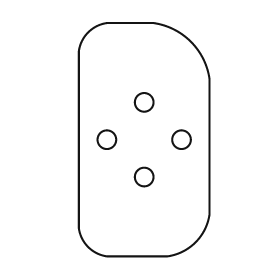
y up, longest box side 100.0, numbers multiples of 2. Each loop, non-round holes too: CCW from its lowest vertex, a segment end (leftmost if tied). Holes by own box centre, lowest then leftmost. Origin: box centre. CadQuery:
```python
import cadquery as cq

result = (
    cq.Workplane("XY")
    .moveTo(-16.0, -50.0)
    .lineTo(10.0, -50.0)
    .threePointArc((22.0, -44.0), (28.0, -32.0))
    .lineTo(28.0, 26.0)
    .threePointArc((20.0, 42.0), (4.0, 50.0))
    .lineTo(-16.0, 50.0)
    .threePointArc((-24.0, 46.0), (-28.0, 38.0))
    .lineTo(-28.0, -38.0)
    .threePointArc((-24.0, -46.0), (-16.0, -50.0))
    .close()
    .moveTo(0.0, -16.0)
    .circle(4.0)
    .moveTo(-16.0, 0.0)
    .circle(4.0)
    .moveTo(16.0, 0.0)
    .circle(4.0)
    .moveTo(0.0, 16.0)
    .circle(4.0)
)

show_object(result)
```